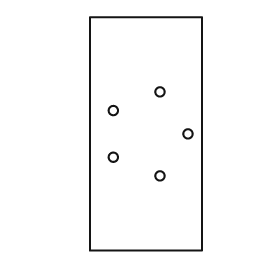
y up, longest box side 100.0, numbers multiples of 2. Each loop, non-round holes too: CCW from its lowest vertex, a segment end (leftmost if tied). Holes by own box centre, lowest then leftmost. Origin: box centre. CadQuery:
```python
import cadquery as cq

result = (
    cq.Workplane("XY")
    .moveTo(-24.0, -50.0)
    .lineTo(24.0, -50.0)
    .lineTo(24.0, 50.0)
    .lineTo(-24.0, 50.0)
    .close()
    .moveTo(6.0, -18.0)
    .circle(2.0)
    .moveTo(-14.0, -10.0)
    .circle(2.0)
    .moveTo(18.0, 0.0)
    .circle(2.0)
    .moveTo(-14.0, 10.0)
    .circle(2.0)
    .moveTo(6.0, 18.0)
    .circle(2.0)
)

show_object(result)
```